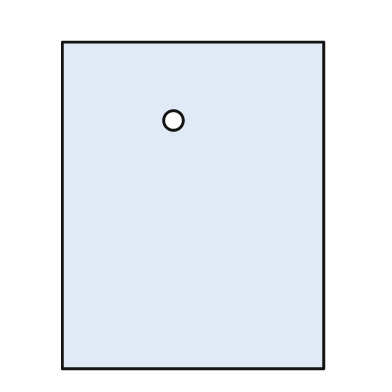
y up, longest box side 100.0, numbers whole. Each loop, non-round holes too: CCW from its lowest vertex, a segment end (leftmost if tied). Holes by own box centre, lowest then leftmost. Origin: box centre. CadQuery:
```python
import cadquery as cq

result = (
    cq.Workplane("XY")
    .moveTo(-40.0, -50.0)
    .lineTo(40.0, -50.0)
    .lineTo(40.0, 50.0)
    .lineTo(-40.0, 50.0)
    .close()
    .moveTo(-6.0, 26.0)
    .circle(3.0)
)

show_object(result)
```